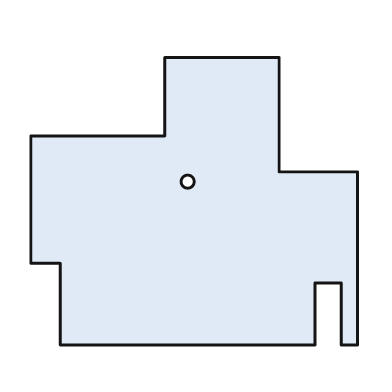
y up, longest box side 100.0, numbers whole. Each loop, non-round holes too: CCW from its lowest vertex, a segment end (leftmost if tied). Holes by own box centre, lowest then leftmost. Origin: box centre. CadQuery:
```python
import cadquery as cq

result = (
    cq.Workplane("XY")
    .moveTo(-41.0, -44.0)
    .lineTo(37.0, -44.0)
    .lineTo(37.0, -25.0)
    .lineTo(45.0, -25.0)
    .lineTo(45.0, -44.0)
    .lineTo(50.0, -44.0)
    .lineTo(50.0, 9.0)
    .lineTo(26.0, 9.0)
    .lineTo(26.0, 44.0)
    .lineTo(-9.0, 44.0)
    .lineTo(-9.0, 20.0)
    .lineTo(-50.0, 20.0)
    .lineTo(-50.0, -19.0)
    .lineTo(-41.0, -19.0)
    .close()
    .moveTo(-2.0, 6.0)
    .circle(2.0)
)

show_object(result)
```